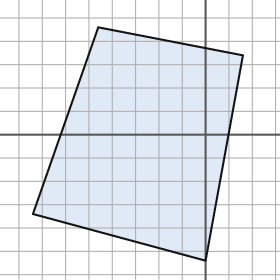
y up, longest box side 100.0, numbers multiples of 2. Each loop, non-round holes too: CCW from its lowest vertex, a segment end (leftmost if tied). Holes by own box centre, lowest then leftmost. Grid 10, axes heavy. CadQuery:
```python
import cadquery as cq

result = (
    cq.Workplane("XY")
    .moveTo(0.0, -54.0)
    .lineTo(16.0, 34.0)
    .lineTo(-46.0, 46.0)
    .lineTo(-74.0, -34.0)
    .close()
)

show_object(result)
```